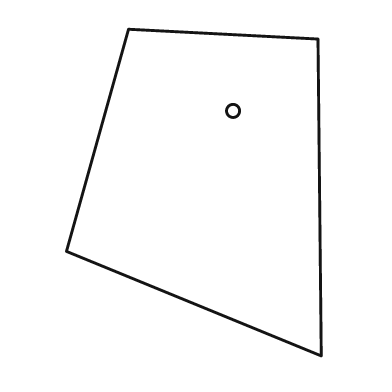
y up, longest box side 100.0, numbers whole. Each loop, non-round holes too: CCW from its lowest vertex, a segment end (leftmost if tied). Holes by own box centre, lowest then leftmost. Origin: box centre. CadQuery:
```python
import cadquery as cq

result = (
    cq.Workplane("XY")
    .moveTo(39.0, -50.0)
    .lineTo(38.0, 47.0)
    .lineTo(-20.0, 50.0)
    .lineTo(-39.0, -18.0)
    .close()
    .moveTo(12.0, 25.0)
    .circle(2.0)
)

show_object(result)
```